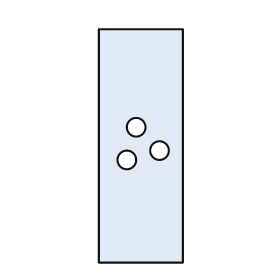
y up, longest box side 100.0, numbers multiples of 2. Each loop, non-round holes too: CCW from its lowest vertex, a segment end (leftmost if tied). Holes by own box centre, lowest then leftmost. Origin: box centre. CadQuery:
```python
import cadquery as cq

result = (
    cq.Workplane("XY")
    .moveTo(-18.0, -50.0)
    .lineTo(18.0, -50.0)
    .lineTo(18.0, 50.0)
    .lineTo(-18.0, 50.0)
    .close()
    .moveTo(-6.0, -6.0)
    .circle(4.0)
    .moveTo(8.0, -2.0)
    .circle(4.0)
    .moveTo(-2.0, 8.0)
    .circle(4.0)
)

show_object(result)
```